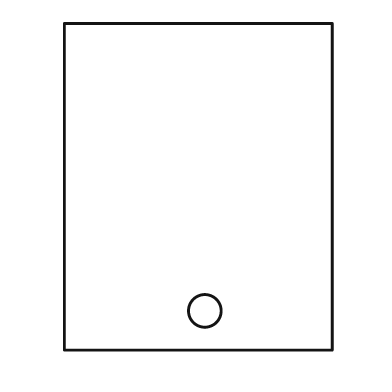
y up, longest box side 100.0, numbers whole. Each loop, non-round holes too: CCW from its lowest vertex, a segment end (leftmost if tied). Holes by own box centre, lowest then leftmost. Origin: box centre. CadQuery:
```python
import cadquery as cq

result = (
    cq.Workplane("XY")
    .moveTo(-41.0, -50.0)
    .lineTo(41.0, -50.0)
    .lineTo(41.0, 50.0)
    .lineTo(-41.0, 50.0)
    .close()
    .moveTo(2.0, -38.0)
    .circle(5.0)
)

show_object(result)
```